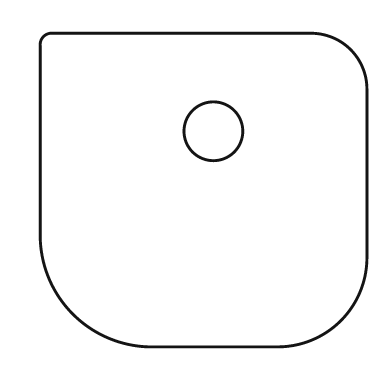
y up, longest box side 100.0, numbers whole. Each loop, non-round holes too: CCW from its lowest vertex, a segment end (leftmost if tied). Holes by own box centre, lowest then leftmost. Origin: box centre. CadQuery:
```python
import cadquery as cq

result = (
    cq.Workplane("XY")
    .moveTo(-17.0, -48.0)
    .lineTo(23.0, -48.0)
    .threePointArc((42.0, -40.0), (50.0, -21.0))
    .lineTo(50.0, 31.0)
    .threePointArc((45.0, 43.0), (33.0, 48.0))
    .lineTo(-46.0, 48.0)
    .threePointArc((-49.0, 47.0), (-50.0, 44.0))
    .lineTo(-50.0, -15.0)
    .threePointArc((-40.0, -38.0), (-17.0, -48.0))
    .close()
    .moveTo(3.0, 18.0)
    .circle(9.0)
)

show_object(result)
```